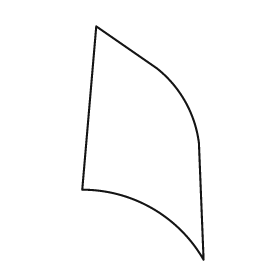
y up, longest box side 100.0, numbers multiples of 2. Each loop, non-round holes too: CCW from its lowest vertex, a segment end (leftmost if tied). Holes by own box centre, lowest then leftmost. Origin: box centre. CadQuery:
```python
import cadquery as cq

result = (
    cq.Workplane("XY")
    .moveTo(26.0, -50.0)
    .lineTo(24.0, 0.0)
    .threePointArc((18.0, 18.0), (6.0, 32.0))
    .lineTo(-20.0, 50.0)
    .lineTo(-26.0, -20.0)
    .threePointArc((4.0, -28.0), (26.0, -50.0))
    .close()
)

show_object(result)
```